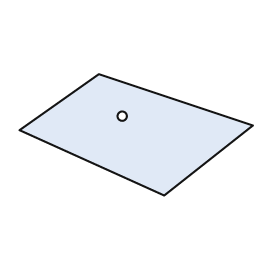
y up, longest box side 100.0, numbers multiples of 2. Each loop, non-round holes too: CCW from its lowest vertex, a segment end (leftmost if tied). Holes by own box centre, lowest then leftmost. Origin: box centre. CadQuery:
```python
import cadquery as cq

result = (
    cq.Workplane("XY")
    .moveTo(12.0, -26.0)
    .lineTo(50.0, 4.0)
    .lineTo(-16.0, 26.0)
    .lineTo(-50.0, 2.0)
    .close()
    .moveTo(-6.0, 8.0)
    .circle(2.0)
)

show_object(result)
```